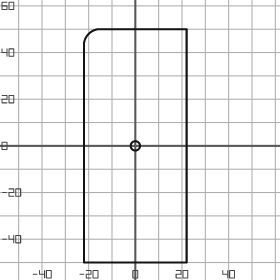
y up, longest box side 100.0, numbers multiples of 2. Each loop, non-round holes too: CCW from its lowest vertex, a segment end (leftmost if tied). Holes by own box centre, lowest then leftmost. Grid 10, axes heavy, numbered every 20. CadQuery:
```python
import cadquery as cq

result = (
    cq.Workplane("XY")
    .moveTo(-22.0, -50.0)
    .lineTo(22.0, -50.0)
    .lineTo(22.0, 50.0)
    .lineTo(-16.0, 50.0)
    .threePointArc((-20.0, 48.0), (-22.0, 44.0))
    .close()
    .moveTo(0.0, 0.0)
    .circle(2.0)
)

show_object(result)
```